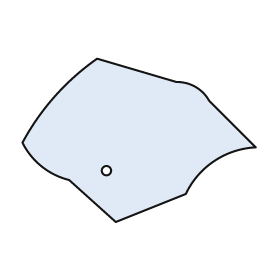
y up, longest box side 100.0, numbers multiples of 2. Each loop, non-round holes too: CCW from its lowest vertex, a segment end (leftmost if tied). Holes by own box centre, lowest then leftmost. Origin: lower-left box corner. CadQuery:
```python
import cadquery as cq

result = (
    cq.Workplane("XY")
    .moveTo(40.0, 0.0)
    .lineTo(70.0, 12.0)
    .threePointArc((82.0, 26.0), (100.0, 32.0))
    .lineTo(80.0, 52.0)
    .threePointArc((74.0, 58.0), (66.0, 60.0))
    .lineTo(32.0, 70.0)
    .threePointArc((14.0, 54.0), (0.0, 34.0))
    .threePointArc((8.0, 24.0), (20.0, 18.0))
    .close()
    .moveTo(36.0, 22.0)
    .circle(2.0)
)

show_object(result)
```